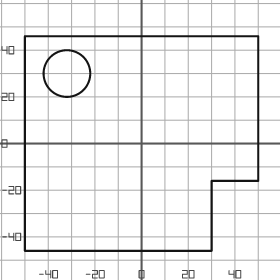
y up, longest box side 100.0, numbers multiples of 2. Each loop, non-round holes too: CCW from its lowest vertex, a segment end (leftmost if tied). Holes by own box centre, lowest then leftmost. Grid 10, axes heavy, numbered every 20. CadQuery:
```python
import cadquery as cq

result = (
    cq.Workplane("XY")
    .moveTo(-50.0, -46.0)
    .lineTo(30.0, -46.0)
    .lineTo(30.0, -16.0)
    .lineTo(50.0, -16.0)
    .lineTo(50.0, 46.0)
    .lineTo(-50.0, 46.0)
    .close()
    .moveTo(-32.0, 30.0)
    .circle(10.0)
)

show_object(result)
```